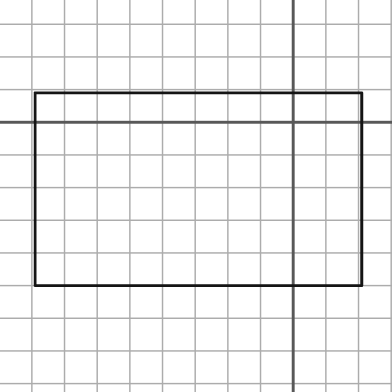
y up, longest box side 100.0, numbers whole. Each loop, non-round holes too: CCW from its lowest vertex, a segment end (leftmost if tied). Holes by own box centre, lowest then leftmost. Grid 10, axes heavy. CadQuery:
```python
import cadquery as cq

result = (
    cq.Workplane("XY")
    .moveTo(-79.0, -50.0)
    .lineTo(21.0, -50.0)
    .lineTo(21.0, 9.0)
    .lineTo(-79.0, 9.0)
    .close()
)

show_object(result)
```